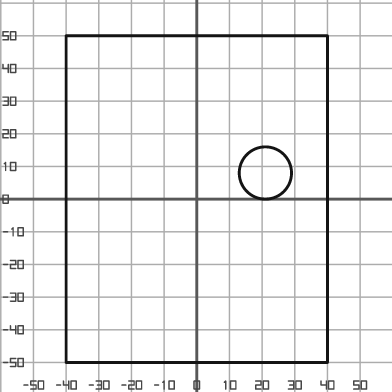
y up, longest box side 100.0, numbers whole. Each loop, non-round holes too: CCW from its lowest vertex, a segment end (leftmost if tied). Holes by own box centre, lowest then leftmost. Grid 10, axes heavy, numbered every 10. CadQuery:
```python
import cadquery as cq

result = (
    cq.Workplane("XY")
    .moveTo(-40.0, -50.0)
    .lineTo(40.0, -50.0)
    .lineTo(40.0, 50.0)
    .lineTo(-40.0, 50.0)
    .close()
    .moveTo(21.0, 8.0)
    .circle(8.0)
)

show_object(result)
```